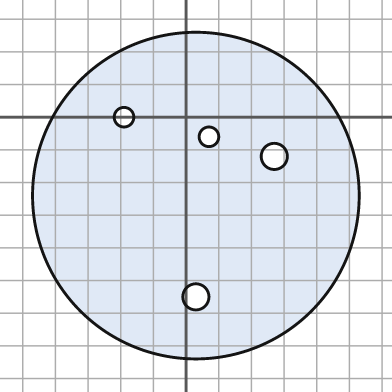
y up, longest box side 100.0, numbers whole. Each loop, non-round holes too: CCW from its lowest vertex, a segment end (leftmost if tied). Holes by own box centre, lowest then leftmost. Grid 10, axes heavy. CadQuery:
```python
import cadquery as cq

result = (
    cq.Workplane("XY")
    .moveTo(3.0, -24.0)
    .circle(50.0)
    .moveTo(3.0, -55.0)
    .circle(4.0)
    .moveTo(27.0, -12.0)
    .circle(4.0)
    .moveTo(7.0, -6.0)
    .circle(3.0)
    .moveTo(-19.0, 0.0)
    .circle(3.0)
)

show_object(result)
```